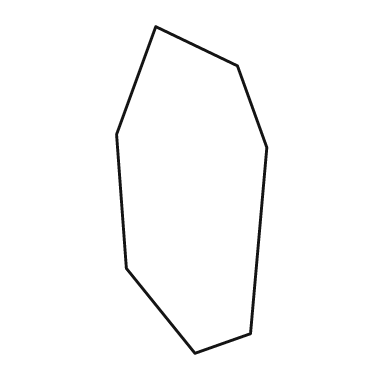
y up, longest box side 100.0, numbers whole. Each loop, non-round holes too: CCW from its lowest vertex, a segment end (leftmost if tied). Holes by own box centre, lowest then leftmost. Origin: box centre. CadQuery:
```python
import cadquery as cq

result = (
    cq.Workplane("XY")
    .moveTo(1.0, -50.0)
    .lineTo(18.0, -44.0)
    .lineTo(23.0, 13.0)
    .lineTo(14.0, 38.0)
    .lineTo(-11.0, 50.0)
    .lineTo(-23.0, 17.0)
    .lineTo(-20.0, -24.0)
    .close()
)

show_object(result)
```